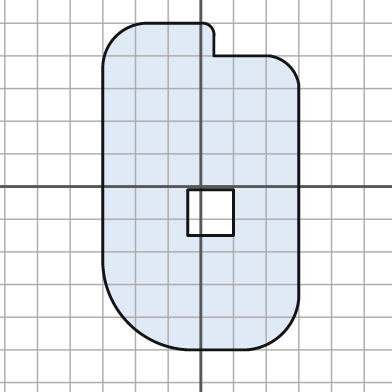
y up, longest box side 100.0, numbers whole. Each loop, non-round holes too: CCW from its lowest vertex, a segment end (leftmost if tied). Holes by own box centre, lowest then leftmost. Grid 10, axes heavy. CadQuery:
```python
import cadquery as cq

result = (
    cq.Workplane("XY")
    .moveTo(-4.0, -50.0)
    .lineTo(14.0, -50.0)
    .threePointArc((25.0, -45.0), (30.0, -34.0))
    .lineTo(30.0, 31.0)
    .threePointArc((27.0, 37.0), (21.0, 40.0))
    .lineTo(4.0, 40.0)
    .lineTo(4.0, 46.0)
    .threePointArc((3.0, 49.0), (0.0, 50.0))
    .lineTo(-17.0, 50.0)
    .threePointArc((-26.0, 46.0), (-30.0, 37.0))
    .lineTo(-30.0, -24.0)
    .threePointArc((-22.0, -42.0), (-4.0, -50.0))
    .close()
    .moveTo(-4.0, -15.0)
    .lineTo(10.0, -15.0)
    .lineTo(10.0, -1.0)
    .lineTo(-4.0, -1.0)
    .close()
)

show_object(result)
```